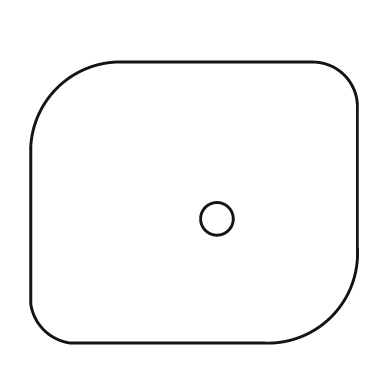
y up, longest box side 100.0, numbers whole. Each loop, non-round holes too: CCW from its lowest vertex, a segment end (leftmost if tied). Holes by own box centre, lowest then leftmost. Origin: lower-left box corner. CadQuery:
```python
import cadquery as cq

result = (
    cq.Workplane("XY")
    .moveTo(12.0, 0.0)
    .lineTo(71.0, 0.0)
    .threePointArc((92.0, 8.0), (100.0, 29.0))
    .lineTo(100.0, 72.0)
    .threePointArc((96.0, 82.0), (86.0, 86.0))
    .lineTo(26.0, 86.0)
    .threePointArc((8.0, 78.0), (0.0, 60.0))
    .lineTo(0.0, 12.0)
    .threePointArc((4.0, 4.0), (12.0, 0.0))
    .close()
    .moveTo(57.0, 38.0)
    .circle(5.0)
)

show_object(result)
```